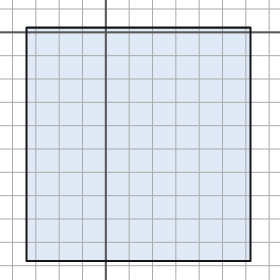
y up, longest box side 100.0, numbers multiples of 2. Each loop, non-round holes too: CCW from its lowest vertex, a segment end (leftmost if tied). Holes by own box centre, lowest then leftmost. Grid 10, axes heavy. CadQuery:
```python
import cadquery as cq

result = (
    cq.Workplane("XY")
    .moveTo(-34.0, -98.0)
    .lineTo(62.0, -98.0)
    .lineTo(62.0, 2.0)
    .lineTo(-34.0, 2.0)
    .close()
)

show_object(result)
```